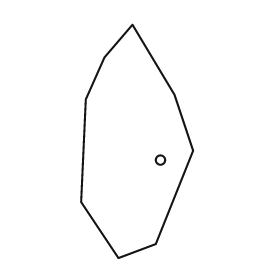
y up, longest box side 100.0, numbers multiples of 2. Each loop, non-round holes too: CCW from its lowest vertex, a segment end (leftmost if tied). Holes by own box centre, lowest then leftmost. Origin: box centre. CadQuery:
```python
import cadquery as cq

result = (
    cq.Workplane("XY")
    .moveTo(-8.0, -50.0)
    .lineTo(8.0, -44.0)
    .lineTo(24.0, -4.0)
    .lineTo(16.0, 20.0)
    .lineTo(-2.0, 50.0)
    .lineTo(-14.0, 36.0)
    .lineTo(-22.0, 18.0)
    .lineTo(-24.0, -26.0)
    .close()
    .moveTo(10.0, -8.0)
    .circle(2.0)
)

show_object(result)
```